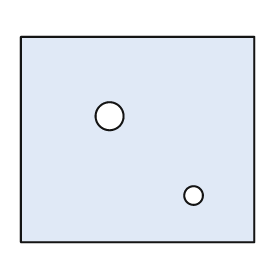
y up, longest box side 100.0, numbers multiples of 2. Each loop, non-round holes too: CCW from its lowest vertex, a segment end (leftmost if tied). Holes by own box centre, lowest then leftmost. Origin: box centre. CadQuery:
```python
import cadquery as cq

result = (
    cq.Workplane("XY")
    .moveTo(-50.0, -44.0)
    .lineTo(50.0, -44.0)
    .lineTo(50.0, 44.0)
    .lineTo(-50.0, 44.0)
    .close()
    .moveTo(24.0, -24.0)
    .circle(4.0)
    .moveTo(-12.0, 10.0)
    .circle(6.0)
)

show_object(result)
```